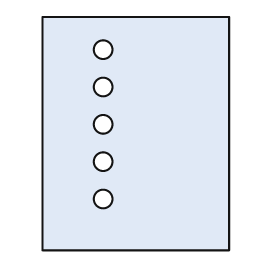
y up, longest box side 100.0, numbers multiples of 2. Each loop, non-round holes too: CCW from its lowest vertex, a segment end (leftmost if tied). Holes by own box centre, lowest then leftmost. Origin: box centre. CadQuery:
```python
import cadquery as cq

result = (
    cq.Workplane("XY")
    .moveTo(-40.0, -50.0)
    .lineTo(40.0, -50.0)
    .lineTo(40.0, 50.0)
    .lineTo(-40.0, 50.0)
    .close()
    .moveTo(-14.0, -28.0)
    .circle(4.0)
    .moveTo(-14.0, -12.0)
    .circle(4.0)
    .moveTo(-14.0, 4.0)
    .circle(4.0)
    .moveTo(-14.0, 20.0)
    .circle(4.0)
    .moveTo(-14.0, 36.0)
    .circle(4.0)
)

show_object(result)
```